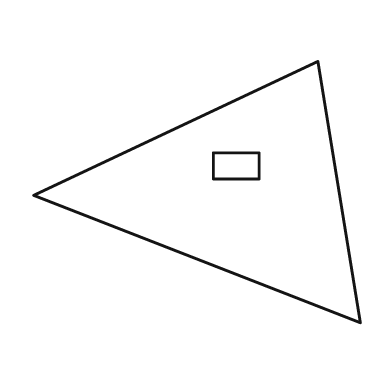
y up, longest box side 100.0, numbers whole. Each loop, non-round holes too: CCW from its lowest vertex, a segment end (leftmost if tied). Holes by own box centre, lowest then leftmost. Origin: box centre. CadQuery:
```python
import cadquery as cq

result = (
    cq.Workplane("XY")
    .moveTo(50.0, -40.0)
    .lineTo(37.0, 40.0)
    .lineTo(-50.0, -1.0)
    .close()
    .moveTo(5.0, 4.0)
    .lineTo(19.0, 4.0)
    .lineTo(19.0, 12.0)
    .lineTo(5.0, 12.0)
    .close()
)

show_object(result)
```